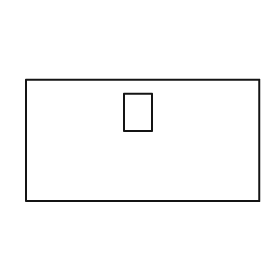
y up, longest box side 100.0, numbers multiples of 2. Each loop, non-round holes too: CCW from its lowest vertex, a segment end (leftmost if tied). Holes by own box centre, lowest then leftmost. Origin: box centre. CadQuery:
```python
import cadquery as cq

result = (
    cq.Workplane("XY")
    .moveTo(-50.0, -26.0)
    .lineTo(50.0, -26.0)
    .lineTo(50.0, 26.0)
    .lineTo(-50.0, 26.0)
    .close()
    .moveTo(-8.0, 4.0)
    .lineTo(4.0, 4.0)
    .lineTo(4.0, 20.0)
    .lineTo(-8.0, 20.0)
    .close()
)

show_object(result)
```